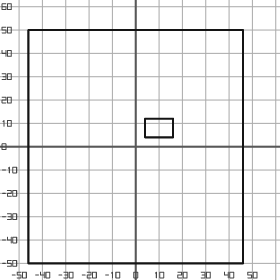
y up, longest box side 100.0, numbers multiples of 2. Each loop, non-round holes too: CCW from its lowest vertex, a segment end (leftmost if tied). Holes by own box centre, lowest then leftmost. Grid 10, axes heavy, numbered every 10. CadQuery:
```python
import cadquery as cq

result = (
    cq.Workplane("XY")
    .moveTo(-46.0, -50.0)
    .lineTo(46.0, -50.0)
    .lineTo(46.0, 50.0)
    .lineTo(-46.0, 50.0)
    .close()
    .moveTo(4.0, 4.0)
    .lineTo(16.0, 4.0)
    .lineTo(16.0, 12.0)
    .lineTo(4.0, 12.0)
    .close()
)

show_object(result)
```